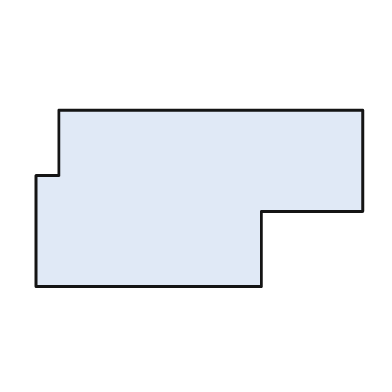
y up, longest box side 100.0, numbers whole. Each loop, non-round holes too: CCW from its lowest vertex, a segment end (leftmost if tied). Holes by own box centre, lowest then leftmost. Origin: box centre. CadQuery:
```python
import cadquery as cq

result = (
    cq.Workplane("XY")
    .moveTo(-50.0, -27.0)
    .lineTo(19.0, -27.0)
    .lineTo(19.0, -4.0)
    .lineTo(50.0, -4.0)
    .lineTo(50.0, 27.0)
    .lineTo(-43.0, 27.0)
    .lineTo(-43.0, 7.0)
    .lineTo(-50.0, 7.0)
    .close()
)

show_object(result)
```